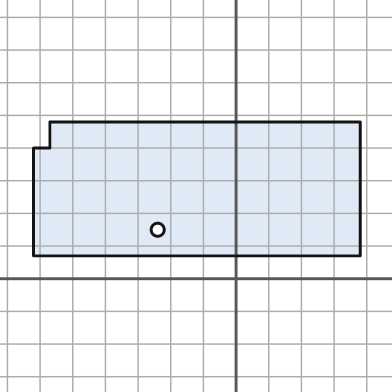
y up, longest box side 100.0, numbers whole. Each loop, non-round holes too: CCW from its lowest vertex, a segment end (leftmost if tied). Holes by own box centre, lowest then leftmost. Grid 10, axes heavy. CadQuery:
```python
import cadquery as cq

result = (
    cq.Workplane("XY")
    .moveTo(-62.0, 7.0)
    .lineTo(38.0, 7.0)
    .lineTo(38.0, 48.0)
    .lineTo(-57.0, 48.0)
    .lineTo(-57.0, 40.0)
    .lineTo(-62.0, 40.0)
    .close()
    .moveTo(-24.0, 15.0)
    .circle(2.0)
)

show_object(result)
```